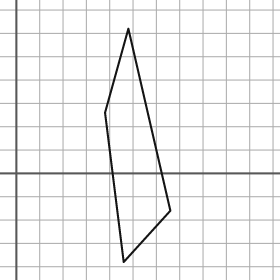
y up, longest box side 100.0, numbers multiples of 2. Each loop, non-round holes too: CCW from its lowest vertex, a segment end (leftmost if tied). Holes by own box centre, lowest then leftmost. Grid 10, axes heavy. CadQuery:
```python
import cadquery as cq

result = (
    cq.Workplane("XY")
    .moveTo(46.0, -38.0)
    .lineTo(66.0, -16.0)
    .lineTo(48.0, 62.0)
    .lineTo(38.0, 26.0)
    .close()
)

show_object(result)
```